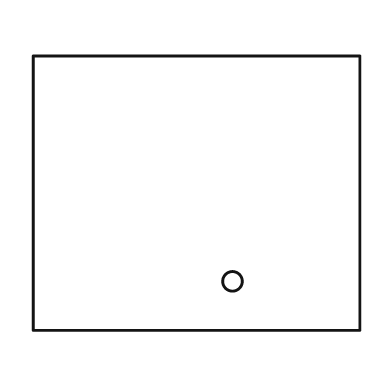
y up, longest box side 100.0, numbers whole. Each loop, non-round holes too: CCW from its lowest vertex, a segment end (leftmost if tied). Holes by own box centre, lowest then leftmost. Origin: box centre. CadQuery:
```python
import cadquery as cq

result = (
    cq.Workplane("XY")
    .moveTo(-50.0, -42.0)
    .lineTo(50.0, -42.0)
    .lineTo(50.0, 42.0)
    .lineTo(-50.0, 42.0)
    .close()
    .moveTo(11.0, -27.0)
    .circle(3.0)
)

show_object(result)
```